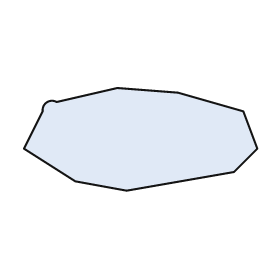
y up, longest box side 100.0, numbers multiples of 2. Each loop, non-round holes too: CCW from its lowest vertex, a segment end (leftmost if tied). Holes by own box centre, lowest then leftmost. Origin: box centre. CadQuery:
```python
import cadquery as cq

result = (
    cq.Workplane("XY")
    .moveTo(-6.0, -22.0)
    .lineTo(40.0, -14.0)
    .lineTo(50.0, -4.0)
    .lineTo(44.0, 12.0)
    .lineTo(16.0, 20.0)
    .lineTo(-10.0, 22.0)
    .lineTo(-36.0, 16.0)
    .threePointArc((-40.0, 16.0), (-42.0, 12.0))
    .lineTo(-50.0, -4.0)
    .lineTo(-28.0, -18.0)
    .close()
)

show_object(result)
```